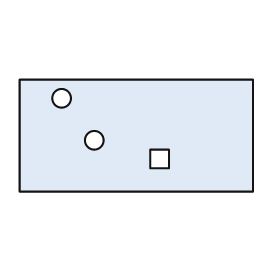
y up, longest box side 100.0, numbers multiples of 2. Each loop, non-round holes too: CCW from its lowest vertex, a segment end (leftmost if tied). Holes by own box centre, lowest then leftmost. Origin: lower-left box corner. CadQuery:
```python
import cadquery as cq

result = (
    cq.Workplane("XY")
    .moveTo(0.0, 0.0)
    .lineTo(100.0, 0.0)
    .lineTo(100.0, 48.0)
    .lineTo(0.0, 48.0)
    .close()
    .moveTo(56.0, 10.0)
    .lineTo(64.0, 10.0)
    .lineTo(64.0, 18.0)
    .lineTo(56.0, 18.0)
    .close()
    .moveTo(32.0, 22.0)
    .circle(4.0)
    .moveTo(18.0, 40.0)
    .circle(4.0)
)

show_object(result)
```